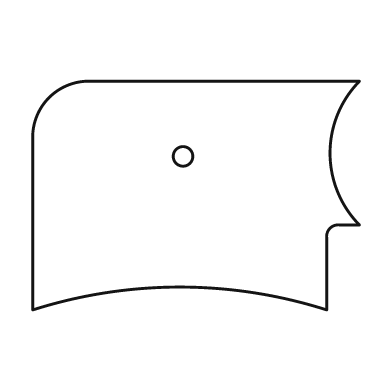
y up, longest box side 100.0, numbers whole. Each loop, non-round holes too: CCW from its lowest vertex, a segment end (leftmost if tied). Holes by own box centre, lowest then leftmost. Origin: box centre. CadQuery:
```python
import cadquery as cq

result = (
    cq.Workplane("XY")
    .moveTo(-50.0, -35.0)
    .threePointArc((-5.0, -28.0), (40.0, -35.0))
    .lineTo(40.0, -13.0)
    .threePointArc((41.0, -10.0), (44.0, -9.0))
    .lineTo(50.0, -9.0)
    .threePointArc((41.0, 13.0), (50.0, 35.0))
    .lineTo(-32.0, 35.0)
    .threePointArc((-45.0, 30.0), (-50.0, 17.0))
    .close()
    .moveTo(-4.0, 12.0)
    .circle(3.0)
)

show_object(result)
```